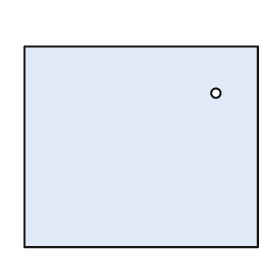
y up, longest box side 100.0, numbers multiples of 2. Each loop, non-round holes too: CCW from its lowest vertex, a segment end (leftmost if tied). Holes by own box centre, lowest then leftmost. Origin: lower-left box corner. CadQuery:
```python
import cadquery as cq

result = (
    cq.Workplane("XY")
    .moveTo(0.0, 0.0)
    .lineTo(100.0, 0.0)
    .lineTo(100.0, 86.0)
    .lineTo(0.0, 86.0)
    .close()
    .moveTo(82.0, 66.0)
    .circle(2.0)
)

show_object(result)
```